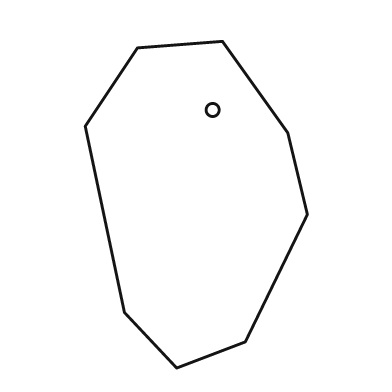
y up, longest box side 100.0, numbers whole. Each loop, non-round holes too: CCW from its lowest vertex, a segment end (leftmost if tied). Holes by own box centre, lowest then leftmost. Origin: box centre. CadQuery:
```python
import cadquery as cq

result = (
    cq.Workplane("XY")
    .moveTo(-6.0, -50.0)
    .lineTo(15.0, -42.0)
    .lineTo(34.0, -3.0)
    .lineTo(28.0, 22.0)
    .lineTo(8.0, 50.0)
    .lineTo(-18.0, 48.0)
    .lineTo(-34.0, 24.0)
    .lineTo(-22.0, -33.0)
    .close()
    .moveTo(5.0, 29.0)
    .circle(2.0)
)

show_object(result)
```